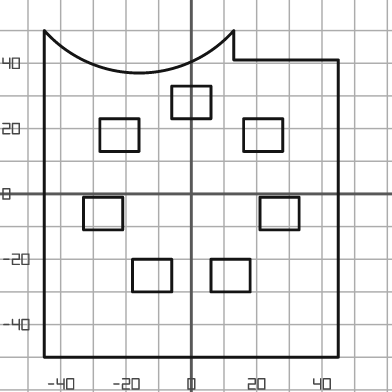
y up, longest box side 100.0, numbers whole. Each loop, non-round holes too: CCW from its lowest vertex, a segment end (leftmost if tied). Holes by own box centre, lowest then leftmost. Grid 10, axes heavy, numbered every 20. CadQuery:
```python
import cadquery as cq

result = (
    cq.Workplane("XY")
    .moveTo(-45.0, -50.0)
    .lineTo(45.0, -50.0)
    .lineTo(45.0, 41.0)
    .lineTo(13.0, 41.0)
    .lineTo(13.0, 50.0)
    .threePointArc((-16.0, 37.0), (-45.0, 50.0))
    .close()
    .moveTo(-18.0, -30.0)
    .lineTo(-6.0, -30.0)
    .lineTo(-6.0, -20.0)
    .lineTo(-18.0, -20.0)
    .close()
    .moveTo(6.0, -30.0)
    .lineTo(18.0, -30.0)
    .lineTo(18.0, -20.0)
    .lineTo(6.0, -20.0)
    .close()
    .moveTo(-33.0, -11.0)
    .lineTo(-21.0, -11.0)
    .lineTo(-21.0, -1.0)
    .lineTo(-33.0, -1.0)
    .close()
    .moveTo(21.0, -11.0)
    .lineTo(33.0, -11.0)
    .lineTo(33.0, -1.0)
    .lineTo(21.0, -1.0)
    .close()
    .moveTo(-28.0, 13.0)
    .lineTo(-16.0, 13.0)
    .lineTo(-16.0, 23.0)
    .lineTo(-28.0, 23.0)
    .close()
    .moveTo(16.0, 13.0)
    .lineTo(28.0, 13.0)
    .lineTo(28.0, 23.0)
    .lineTo(16.0, 23.0)
    .close()
    .moveTo(-6.0, 23.0)
    .lineTo(6.0, 23.0)
    .lineTo(6.0, 33.0)
    .lineTo(-6.0, 33.0)
    .close()
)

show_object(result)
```